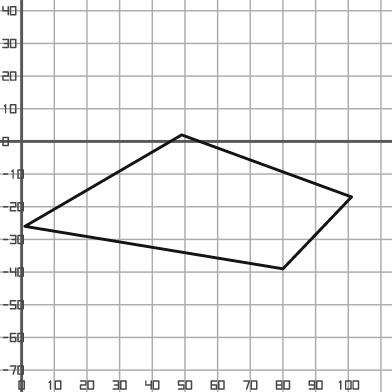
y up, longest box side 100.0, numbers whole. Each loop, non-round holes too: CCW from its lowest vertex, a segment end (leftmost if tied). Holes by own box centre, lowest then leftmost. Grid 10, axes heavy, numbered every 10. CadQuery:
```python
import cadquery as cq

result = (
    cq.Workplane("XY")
    .moveTo(80.0, -39.0)
    .lineTo(101.0, -17.0)
    .lineTo(49.0, 2.0)
    .lineTo(1.0, -26.0)
    .close()
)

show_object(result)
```